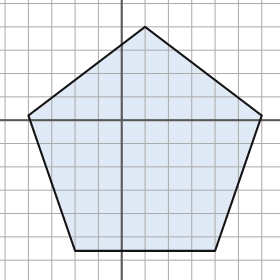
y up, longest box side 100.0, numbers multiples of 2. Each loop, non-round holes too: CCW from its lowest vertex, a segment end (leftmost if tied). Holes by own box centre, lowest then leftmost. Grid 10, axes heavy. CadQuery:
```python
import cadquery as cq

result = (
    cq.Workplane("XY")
    .moveTo(-20.0, -56.0)
    .lineTo(40.0, -56.0)
    .lineTo(60.0, 2.0)
    .lineTo(10.0, 40.0)
    .lineTo(-40.0, 2.0)
    .close()
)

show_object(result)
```